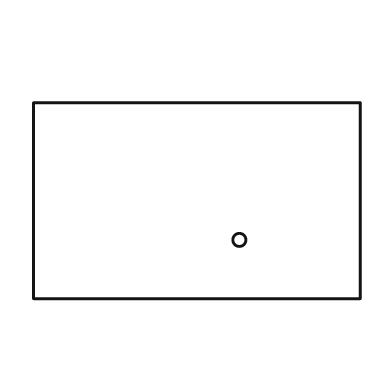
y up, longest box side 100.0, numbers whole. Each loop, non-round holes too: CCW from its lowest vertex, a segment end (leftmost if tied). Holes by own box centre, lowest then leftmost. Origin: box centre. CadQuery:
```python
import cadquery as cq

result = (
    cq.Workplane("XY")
    .moveTo(-50.0, -30.0)
    .lineTo(50.0, -30.0)
    .lineTo(50.0, 30.0)
    .lineTo(-50.0, 30.0)
    .close()
    .moveTo(13.0, -12.0)
    .circle(2.0)
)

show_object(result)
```